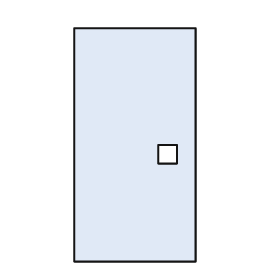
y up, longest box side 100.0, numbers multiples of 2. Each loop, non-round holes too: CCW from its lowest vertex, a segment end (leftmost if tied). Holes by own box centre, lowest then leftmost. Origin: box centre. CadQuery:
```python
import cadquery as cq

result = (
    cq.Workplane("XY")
    .moveTo(-26.0, -50.0)
    .lineTo(26.0, -50.0)
    .lineTo(26.0, 50.0)
    .lineTo(-26.0, 50.0)
    .close()
    .moveTo(10.0, -8.0)
    .lineTo(18.0, -8.0)
    .lineTo(18.0, 0.0)
    .lineTo(10.0, 0.0)
    .close()
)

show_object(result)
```